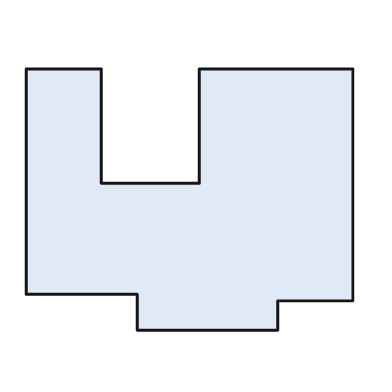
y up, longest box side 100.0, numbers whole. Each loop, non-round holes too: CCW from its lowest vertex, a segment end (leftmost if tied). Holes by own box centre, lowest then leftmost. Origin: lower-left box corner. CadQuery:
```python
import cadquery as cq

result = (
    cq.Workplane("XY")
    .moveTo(34.0, 0.0)
    .lineTo(77.0, 0.0)
    .lineTo(77.0, 9.0)
    .lineTo(100.0, 9.0)
    .lineTo(100.0, 80.0)
    .lineTo(53.0, 80.0)
    .lineTo(53.0, 45.0)
    .lineTo(23.0, 45.0)
    .lineTo(23.0, 80.0)
    .lineTo(0.0, 80.0)
    .lineTo(0.0, 11.0)
    .lineTo(34.0, 11.0)
    .close()
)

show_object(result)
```